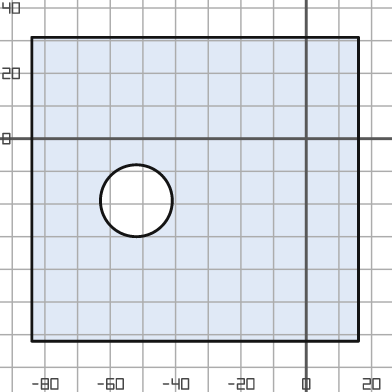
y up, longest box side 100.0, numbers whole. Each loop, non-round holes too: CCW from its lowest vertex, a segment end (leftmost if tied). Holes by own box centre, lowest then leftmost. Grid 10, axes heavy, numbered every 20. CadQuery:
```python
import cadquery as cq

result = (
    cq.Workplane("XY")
    .moveTo(-84.0, -62.0)
    .lineTo(16.0, -62.0)
    .lineTo(16.0, 31.0)
    .lineTo(-84.0, 31.0)
    .close()
    .moveTo(-52.0, -19.0)
    .circle(11.0)
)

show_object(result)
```